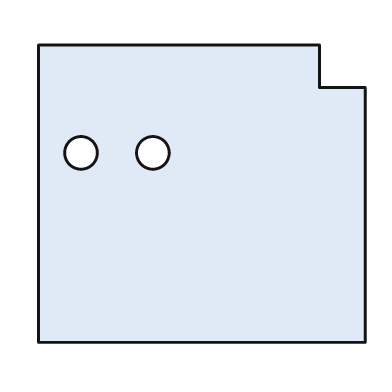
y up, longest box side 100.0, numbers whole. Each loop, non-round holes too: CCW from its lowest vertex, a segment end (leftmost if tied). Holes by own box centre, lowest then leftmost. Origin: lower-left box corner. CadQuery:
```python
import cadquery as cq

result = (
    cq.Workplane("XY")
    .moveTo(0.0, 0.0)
    .lineTo(100.0, 0.0)
    .lineTo(100.0, 78.0)
    .lineTo(86.0, 78.0)
    .lineTo(86.0, 91.0)
    .lineTo(0.0, 91.0)
    .close()
    .moveTo(13.0, 58.0)
    .circle(5.0)
    .moveTo(35.0, 58.0)
    .circle(5.0)
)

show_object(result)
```